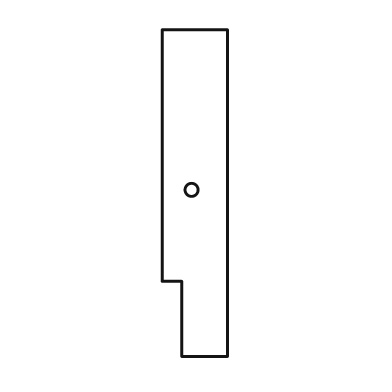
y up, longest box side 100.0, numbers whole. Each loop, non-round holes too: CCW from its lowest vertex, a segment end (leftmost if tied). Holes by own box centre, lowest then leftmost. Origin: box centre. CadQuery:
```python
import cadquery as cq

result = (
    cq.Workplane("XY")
    .moveTo(-4.0, -50.0)
    .lineTo(10.0, -50.0)
    .lineTo(10.0, 50.0)
    .lineTo(-10.0, 50.0)
    .lineTo(-10.0, -27.0)
    .lineTo(-4.0, -27.0)
    .close()
    .moveTo(-1.0, 1.0)
    .circle(2.0)
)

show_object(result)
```